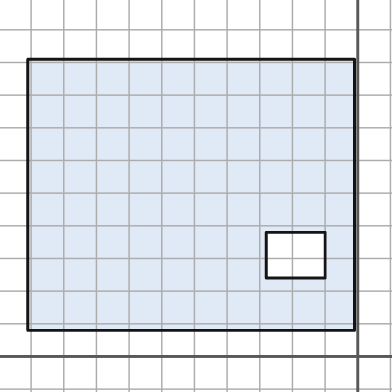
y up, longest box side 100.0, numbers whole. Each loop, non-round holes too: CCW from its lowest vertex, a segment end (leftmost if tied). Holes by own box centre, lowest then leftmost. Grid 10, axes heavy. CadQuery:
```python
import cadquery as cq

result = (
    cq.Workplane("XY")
    .moveTo(-101.0, 8.0)
    .lineTo(-1.0, 8.0)
    .lineTo(-1.0, 91.0)
    .lineTo(-101.0, 91.0)
    .close()
    .moveTo(-28.0, 24.0)
    .lineTo(-10.0, 24.0)
    .lineTo(-10.0, 38.0)
    .lineTo(-28.0, 38.0)
    .close()
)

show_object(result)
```